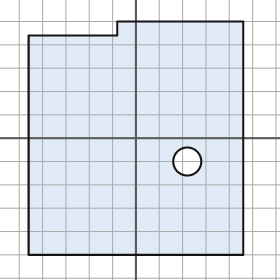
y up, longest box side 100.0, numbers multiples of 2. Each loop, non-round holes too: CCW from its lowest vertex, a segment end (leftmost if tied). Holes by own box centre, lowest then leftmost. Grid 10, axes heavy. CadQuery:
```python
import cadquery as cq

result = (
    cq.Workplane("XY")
    .moveTo(-46.0, -50.0)
    .lineTo(46.0, -50.0)
    .lineTo(46.0, 50.0)
    .lineTo(-8.0, 50.0)
    .lineTo(-8.0, 44.0)
    .lineTo(-46.0, 44.0)
    .close()
    .moveTo(22.0, -10.0)
    .circle(6.0)
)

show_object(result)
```